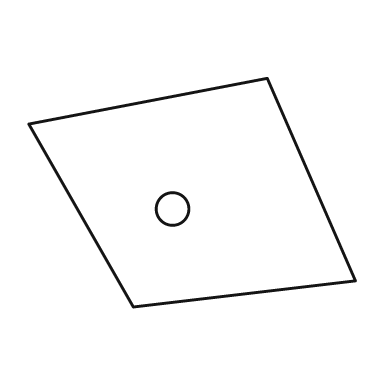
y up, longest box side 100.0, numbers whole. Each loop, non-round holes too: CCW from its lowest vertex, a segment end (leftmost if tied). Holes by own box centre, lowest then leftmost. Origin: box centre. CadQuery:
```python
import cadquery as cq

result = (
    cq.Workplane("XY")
    .moveTo(-18.0, -35.0)
    .lineTo(50.0, -27.0)
    .lineTo(23.0, 35.0)
    .lineTo(-50.0, 21.0)
    .close()
    .moveTo(-6.0, -5.0)
    .circle(5.0)
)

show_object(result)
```